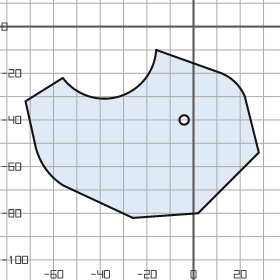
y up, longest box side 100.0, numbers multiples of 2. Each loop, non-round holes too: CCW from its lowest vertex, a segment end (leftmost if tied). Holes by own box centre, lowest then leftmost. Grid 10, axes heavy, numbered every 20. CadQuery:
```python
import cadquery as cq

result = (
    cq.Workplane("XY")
    .moveTo(-26.0, -82.0)
    .lineTo(2.0, -80.0)
    .lineTo(28.0, -54.0)
    .lineTo(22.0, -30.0)
    .threePointArc((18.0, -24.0), (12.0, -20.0))
    .lineTo(-16.0, -10.0)
    .threePointArc((-32.0, -30.0), (-56.0, -22.0))
    .lineTo(-72.0, -32.0)
    .lineTo(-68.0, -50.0)
    .threePointArc((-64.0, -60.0), (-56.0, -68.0))
    .close()
    .moveTo(-4.0, -40.0)
    .circle(2.0)
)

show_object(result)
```